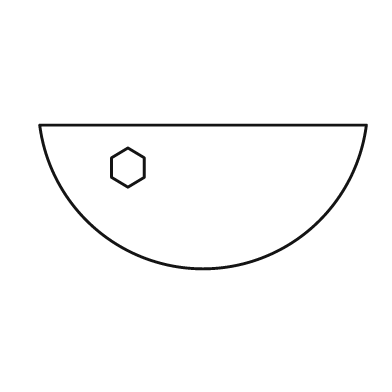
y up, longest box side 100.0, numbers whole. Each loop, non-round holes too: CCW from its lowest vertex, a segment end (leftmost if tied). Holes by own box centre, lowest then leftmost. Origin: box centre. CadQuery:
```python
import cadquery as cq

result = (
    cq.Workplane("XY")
    .moveTo(-50.0, 22.0)
    .threePointArc((0.0, -22.0), (50.0, 22.0))
    .close()
    .moveTo(-23.0, 3.0)
    .lineTo(-18.0, 6.0)
    .lineTo(-18.0, 12.0)
    .lineTo(-23.0, 15.0)
    .lineTo(-28.0, 12.0)
    .lineTo(-28.0, 6.0)
    .close()
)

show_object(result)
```